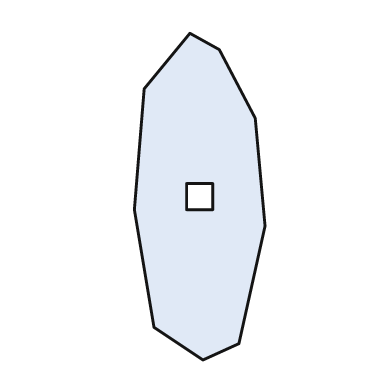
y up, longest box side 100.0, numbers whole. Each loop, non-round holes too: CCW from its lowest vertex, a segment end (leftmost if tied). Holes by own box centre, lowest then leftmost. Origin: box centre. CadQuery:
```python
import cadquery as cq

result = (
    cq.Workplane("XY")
    .moveTo(1.0, -50.0)
    .lineTo(12.0, -45.0)
    .lineTo(20.0, -9.0)
    .lineTo(17.0, 24.0)
    .lineTo(6.0, 45.0)
    .lineTo(-3.0, 50.0)
    .lineTo(-17.0, 33.0)
    .lineTo(-20.0, -4.0)
    .lineTo(-14.0, -40.0)
    .close()
    .moveTo(-4.0, -4.0)
    .lineTo(4.0, -4.0)
    .lineTo(4.0, 4.0)
    .lineTo(-4.0, 4.0)
    .close()
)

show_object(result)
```